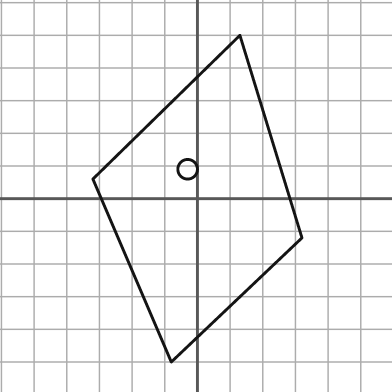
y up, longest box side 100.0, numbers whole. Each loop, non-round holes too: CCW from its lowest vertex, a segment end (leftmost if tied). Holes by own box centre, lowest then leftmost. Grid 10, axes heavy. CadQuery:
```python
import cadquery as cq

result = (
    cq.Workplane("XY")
    .moveTo(-8.0, -50.0)
    .lineTo(32.0, -12.0)
    .lineTo(13.0, 50.0)
    .lineTo(-32.0, 6.0)
    .close()
    .moveTo(-3.0, 9.0)
    .circle(3.0)
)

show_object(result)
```